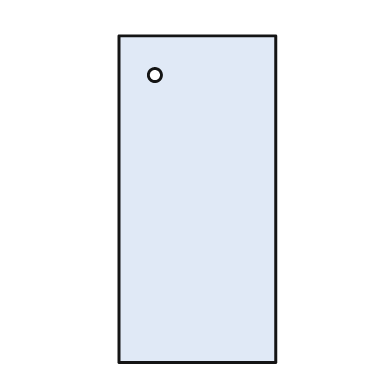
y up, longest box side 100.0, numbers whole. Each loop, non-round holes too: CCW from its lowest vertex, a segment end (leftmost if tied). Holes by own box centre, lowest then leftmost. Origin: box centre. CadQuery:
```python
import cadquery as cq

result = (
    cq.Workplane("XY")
    .moveTo(-24.0, -50.0)
    .lineTo(24.0, -50.0)
    .lineTo(24.0, 50.0)
    .lineTo(-24.0, 50.0)
    .close()
    .moveTo(-13.0, 38.0)
    .circle(2.0)
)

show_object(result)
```